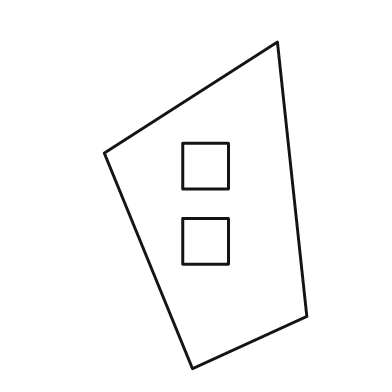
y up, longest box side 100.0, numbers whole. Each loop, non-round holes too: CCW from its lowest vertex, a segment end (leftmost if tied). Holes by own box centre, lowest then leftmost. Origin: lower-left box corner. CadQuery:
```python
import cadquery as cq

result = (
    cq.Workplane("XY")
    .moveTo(27.0, 0.0)
    .lineTo(62.0, 16.0)
    .lineTo(53.0, 100.0)
    .lineTo(0.0, 66.0)
    .close()
    .moveTo(24.0, 32.0)
    .lineTo(38.0, 32.0)
    .lineTo(38.0, 46.0)
    .lineTo(24.0, 46.0)
    .close()
    .moveTo(24.0, 55.0)
    .lineTo(38.0, 55.0)
    .lineTo(38.0, 69.0)
    .lineTo(24.0, 69.0)
    .close()
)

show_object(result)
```